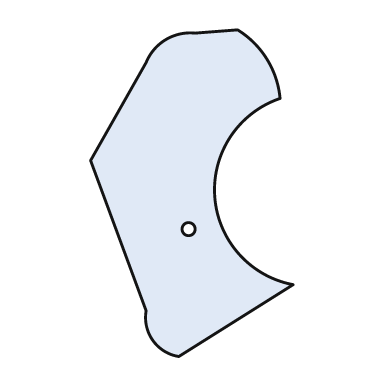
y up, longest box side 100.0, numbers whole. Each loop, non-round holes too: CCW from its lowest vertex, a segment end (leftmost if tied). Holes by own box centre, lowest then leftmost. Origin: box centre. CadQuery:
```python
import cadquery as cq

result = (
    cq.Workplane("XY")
    .moveTo(-4.0, -50.0)
    .lineTo(31.0, -28.0)
    .threePointArc((7.0, -1.0), (27.0, 29.0))
    .threePointArc((23.0, 41.0), (14.0, 50.0))
    .lineTo(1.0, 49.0)
    .threePointArc((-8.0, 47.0), (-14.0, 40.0))
    .lineTo(-31.0, 10.0)
    .lineTo(-14.0, -36.0)
    .threePointArc((-12.0, -45.0), (-4.0, -50.0))
    .close()
    .moveTo(-1.0, -11.0)
    .circle(2.0)
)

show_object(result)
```